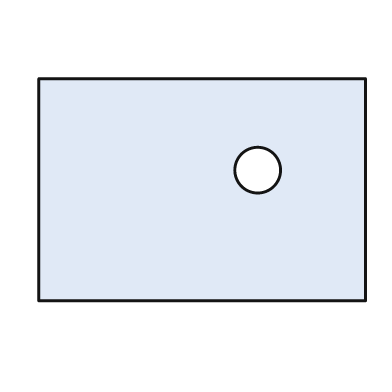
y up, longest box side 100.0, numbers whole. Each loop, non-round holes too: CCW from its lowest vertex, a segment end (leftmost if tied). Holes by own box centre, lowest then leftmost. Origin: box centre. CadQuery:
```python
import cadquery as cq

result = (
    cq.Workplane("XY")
    .moveTo(-50.0, -34.0)
    .lineTo(50.0, -34.0)
    .lineTo(50.0, 34.0)
    .lineTo(-50.0, 34.0)
    .close()
    .moveTo(17.0, 6.0)
    .circle(7.0)
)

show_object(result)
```